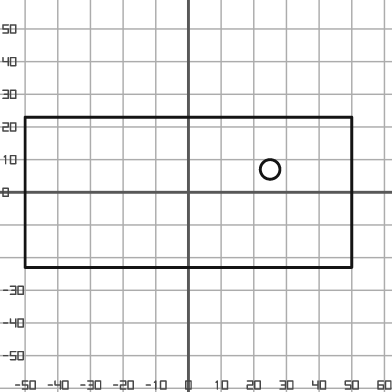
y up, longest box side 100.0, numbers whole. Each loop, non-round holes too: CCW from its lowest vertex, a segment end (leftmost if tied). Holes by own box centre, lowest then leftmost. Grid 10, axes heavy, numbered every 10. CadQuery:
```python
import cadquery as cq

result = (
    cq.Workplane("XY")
    .moveTo(-50.0, -23.0)
    .lineTo(50.0, -23.0)
    .lineTo(50.0, 23.0)
    .lineTo(-50.0, 23.0)
    .close()
    .moveTo(25.0, 7.0)
    .circle(3.0)
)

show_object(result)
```